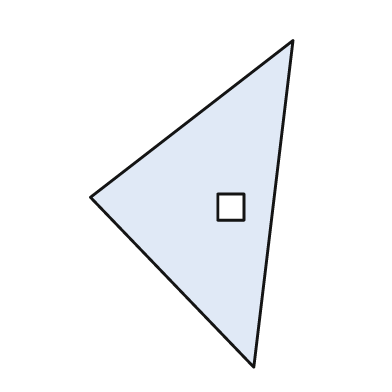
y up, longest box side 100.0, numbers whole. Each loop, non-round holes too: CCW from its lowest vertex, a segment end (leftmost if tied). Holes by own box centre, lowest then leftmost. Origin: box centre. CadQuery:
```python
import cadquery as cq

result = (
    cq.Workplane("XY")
    .moveTo(19.0, -50.0)
    .lineTo(31.0, 50.0)
    .lineTo(-31.0, 2.0)
    .close()
    .moveTo(8.0, -5.0)
    .lineTo(16.0, -5.0)
    .lineTo(16.0, 3.0)
    .lineTo(8.0, 3.0)
    .close()
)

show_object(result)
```